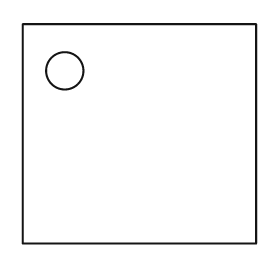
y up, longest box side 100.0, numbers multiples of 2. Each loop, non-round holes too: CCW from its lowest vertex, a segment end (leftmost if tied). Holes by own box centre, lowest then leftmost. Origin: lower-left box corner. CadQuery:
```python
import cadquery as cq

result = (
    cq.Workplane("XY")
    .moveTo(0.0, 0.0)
    .lineTo(100.0, 0.0)
    .lineTo(100.0, 94.0)
    .lineTo(0.0, 94.0)
    .close()
    .moveTo(18.0, 74.0)
    .circle(8.0)
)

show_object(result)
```